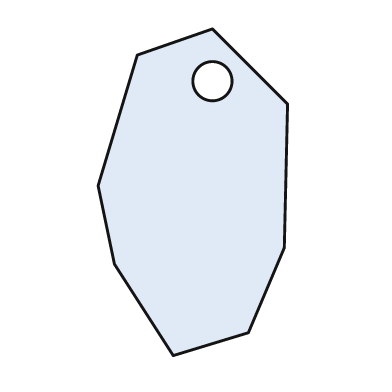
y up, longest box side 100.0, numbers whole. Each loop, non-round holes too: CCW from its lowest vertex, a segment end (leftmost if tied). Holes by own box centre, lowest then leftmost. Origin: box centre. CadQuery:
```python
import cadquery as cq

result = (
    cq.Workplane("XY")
    .moveTo(-6.0, -50.0)
    .lineTo(17.0, -43.0)
    .lineTo(28.0, -17.0)
    .lineTo(29.0, 27.0)
    .lineTo(6.0, 50.0)
    .lineTo(-17.0, 42.0)
    .lineTo(-29.0, 2.0)
    .lineTo(-24.0, -22.0)
    .close()
    .moveTo(6.0, 34.0)
    .circle(6.0)
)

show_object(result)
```